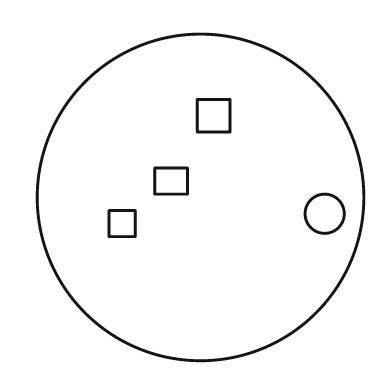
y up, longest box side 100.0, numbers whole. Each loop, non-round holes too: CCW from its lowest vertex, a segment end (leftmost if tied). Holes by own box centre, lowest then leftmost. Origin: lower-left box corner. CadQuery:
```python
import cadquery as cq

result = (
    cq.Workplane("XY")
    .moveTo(50.0, 50.0)
    .circle(50.0)
    .moveTo(22.0, 38.0)
    .lineTo(30.0, 38.0)
    .lineTo(30.0, 46.0)
    .lineTo(22.0, 46.0)
    .close()
    .moveTo(88.0, 45.0)
    .circle(6.0)
    .moveTo(36.0, 51.0)
    .lineTo(46.0, 51.0)
    .lineTo(46.0, 59.0)
    .lineTo(36.0, 59.0)
    .close()
    .moveTo(49.0, 70.0)
    .lineTo(59.0, 70.0)
    .lineTo(59.0, 80.0)
    .lineTo(49.0, 80.0)
    .close()
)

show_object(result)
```